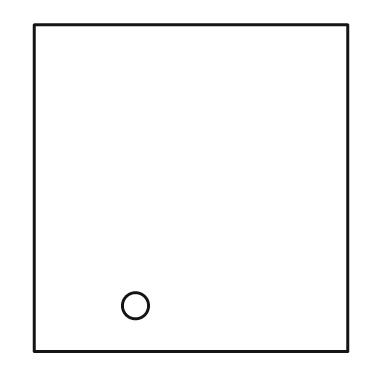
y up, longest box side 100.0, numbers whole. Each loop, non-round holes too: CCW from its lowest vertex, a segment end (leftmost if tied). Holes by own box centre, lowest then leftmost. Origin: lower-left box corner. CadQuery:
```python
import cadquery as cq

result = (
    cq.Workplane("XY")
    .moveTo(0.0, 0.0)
    .lineTo(96.0, 0.0)
    .lineTo(96.0, 100.0)
    .lineTo(0.0, 100.0)
    .close()
    .moveTo(31.0, 14.0)
    .circle(4.0)
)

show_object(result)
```